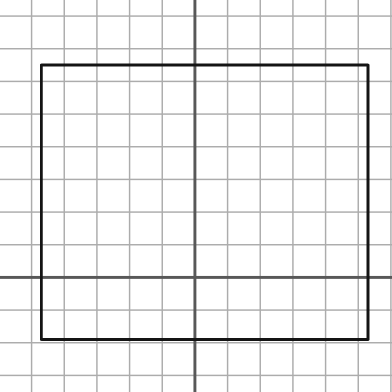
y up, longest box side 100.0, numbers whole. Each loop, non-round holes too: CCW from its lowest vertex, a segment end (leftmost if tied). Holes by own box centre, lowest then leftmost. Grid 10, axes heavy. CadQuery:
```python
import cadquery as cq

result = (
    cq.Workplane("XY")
    .moveTo(-47.0, -19.0)
    .lineTo(53.0, -19.0)
    .lineTo(53.0, 65.0)
    .lineTo(-47.0, 65.0)
    .close()
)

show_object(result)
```